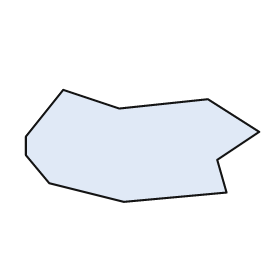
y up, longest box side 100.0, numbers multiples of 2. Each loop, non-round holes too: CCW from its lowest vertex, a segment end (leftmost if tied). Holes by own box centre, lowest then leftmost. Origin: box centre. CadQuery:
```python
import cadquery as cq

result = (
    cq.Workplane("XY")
    .moveTo(-8.0, -24.0)
    .lineTo(36.0, -20.0)
    .lineTo(32.0, -6.0)
    .lineTo(50.0, 6.0)
    .lineTo(28.0, 20.0)
    .lineTo(-10.0, 16.0)
    .lineTo(-34.0, 24.0)
    .lineTo(-50.0, 4.0)
    .lineTo(-50.0, -4.0)
    .lineTo(-40.0, -16.0)
    .close()
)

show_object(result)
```